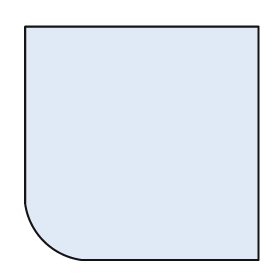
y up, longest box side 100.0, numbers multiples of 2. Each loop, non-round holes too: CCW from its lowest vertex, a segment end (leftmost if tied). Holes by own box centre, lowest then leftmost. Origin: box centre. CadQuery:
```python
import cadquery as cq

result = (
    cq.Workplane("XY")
    .moveTo(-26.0, -50.0)
    .lineTo(50.0, -50.0)
    .lineTo(50.0, 50.0)
    .lineTo(-50.0, 50.0)
    .lineTo(-50.0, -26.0)
    .threePointArc((-42.0, -42.0), (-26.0, -50.0))
    .close()
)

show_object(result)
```